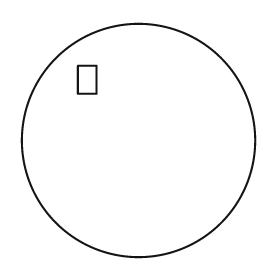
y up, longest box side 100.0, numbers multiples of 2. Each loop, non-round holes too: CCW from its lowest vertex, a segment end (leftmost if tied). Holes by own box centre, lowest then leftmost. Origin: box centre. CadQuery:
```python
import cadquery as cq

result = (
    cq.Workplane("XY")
    .moveTo(0.0, 0.0)
    .circle(50.0)
    .moveTo(-26.0, 20.0)
    .lineTo(-18.0, 20.0)
    .lineTo(-18.0, 32.0)
    .lineTo(-26.0, 32.0)
    .close()
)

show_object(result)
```